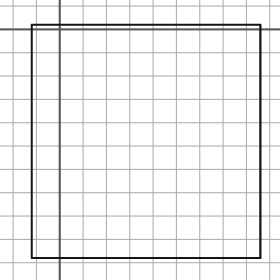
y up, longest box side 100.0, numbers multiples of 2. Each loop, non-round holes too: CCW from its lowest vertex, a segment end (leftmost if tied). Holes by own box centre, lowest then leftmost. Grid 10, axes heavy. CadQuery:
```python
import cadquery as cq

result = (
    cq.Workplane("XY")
    .moveTo(-12.0, -98.0)
    .lineTo(86.0, -98.0)
    .lineTo(86.0, 2.0)
    .lineTo(-12.0, 2.0)
    .close()
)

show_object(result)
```